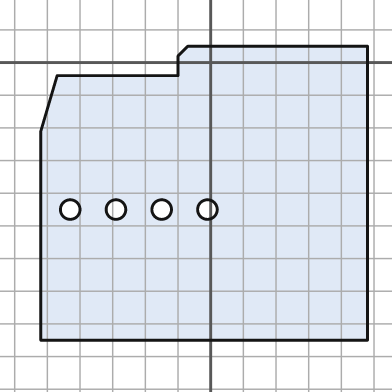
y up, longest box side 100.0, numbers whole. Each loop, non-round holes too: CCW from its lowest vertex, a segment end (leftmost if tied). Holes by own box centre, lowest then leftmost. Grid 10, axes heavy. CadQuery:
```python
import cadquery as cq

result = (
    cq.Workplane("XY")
    .moveTo(-52.0, -85.0)
    .lineTo(48.0, -85.0)
    .lineTo(48.0, 5.0)
    .lineTo(-7.0, 5.0)
    .lineTo(-10.0, 2.0)
    .lineTo(-10.0, -4.0)
    .lineTo(-47.0, -4.0)
    .lineTo(-52.0, -21.0)
    .close()
    .moveTo(-43.0, -45.0)
    .circle(3.0)
    .moveTo(-29.0, -45.0)
    .circle(3.0)
    .moveTo(-15.0, -45.0)
    .circle(3.0)
    .moveTo(-1.0, -45.0)
    .circle(3.0)
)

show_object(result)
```